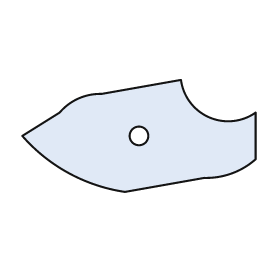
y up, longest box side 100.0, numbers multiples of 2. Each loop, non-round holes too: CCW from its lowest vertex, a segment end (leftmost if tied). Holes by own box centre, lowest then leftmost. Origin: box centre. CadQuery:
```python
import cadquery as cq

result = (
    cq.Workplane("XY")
    .moveTo(-6.0, -24.0)
    .lineTo(28.0, -18.0)
    .threePointArc((40.0, -16.0), (50.0, -10.0))
    .lineTo(50.0, 10.0)
    .threePointArc((30.0, 8.0), (18.0, 24.0))
    .lineTo(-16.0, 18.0)
    .threePointArc((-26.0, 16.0), (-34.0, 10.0))
    .lineTo(-50.0, 0.0)
    .threePointArc((-30.0, -16.0), (-6.0, -24.0))
    .close()
    .moveTo(0.0, 0.0)
    .circle(4.0)
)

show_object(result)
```